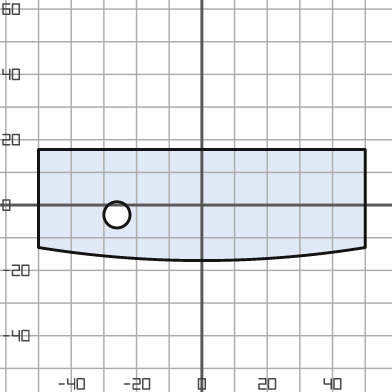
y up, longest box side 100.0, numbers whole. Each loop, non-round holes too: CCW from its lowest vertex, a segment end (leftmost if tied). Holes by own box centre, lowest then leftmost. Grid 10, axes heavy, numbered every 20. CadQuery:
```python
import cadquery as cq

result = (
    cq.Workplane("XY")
    .moveTo(-50.0, -13.0)
    .threePointArc((0.0, -17.0), (50.0, -13.0))
    .lineTo(50.0, 17.0)
    .lineTo(-50.0, 17.0)
    .close()
    .moveTo(-26.0, -3.0)
    .circle(4.0)
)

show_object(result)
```